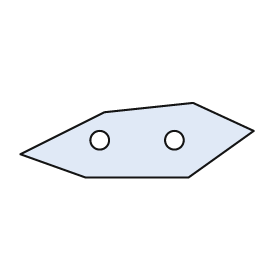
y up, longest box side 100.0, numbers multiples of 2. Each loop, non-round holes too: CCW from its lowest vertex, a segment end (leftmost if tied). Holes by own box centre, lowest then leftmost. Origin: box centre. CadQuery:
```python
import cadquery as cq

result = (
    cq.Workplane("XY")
    .moveTo(-22.0, -16.0)
    .lineTo(22.0, -16.0)
    .lineTo(50.0, 4.0)
    .lineTo(24.0, 16.0)
    .lineTo(-14.0, 12.0)
    .lineTo(-50.0, -6.0)
    .close()
    .moveTo(-16.0, 0.0)
    .circle(4.0)
    .moveTo(16.0, 0.0)
    .circle(4.0)
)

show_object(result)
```